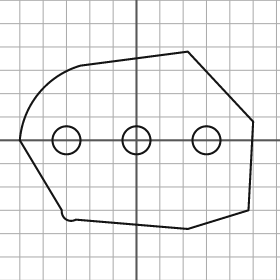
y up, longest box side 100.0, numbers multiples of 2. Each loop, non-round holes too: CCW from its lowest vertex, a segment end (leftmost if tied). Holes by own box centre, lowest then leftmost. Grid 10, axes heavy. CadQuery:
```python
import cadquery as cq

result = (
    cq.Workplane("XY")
    .moveTo(22.0, -38.0)
    .lineTo(48.0, -30.0)
    .lineTo(50.0, 8.0)
    .lineTo(22.0, 38.0)
    .lineTo(-24.0, 32.0)
    .threePointArc((-42.0, 20.0), (-50.0, 0.0))
    .lineTo(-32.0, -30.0)
    .threePointArc((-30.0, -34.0), (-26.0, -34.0))
    .close()
    .moveTo(-30.0, 0.0)
    .circle(6.0)
    .moveTo(0.0, 0.0)
    .circle(6.0)
    .moveTo(30.0, 0.0)
    .circle(6.0)
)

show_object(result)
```